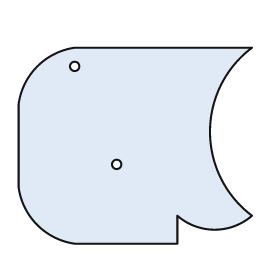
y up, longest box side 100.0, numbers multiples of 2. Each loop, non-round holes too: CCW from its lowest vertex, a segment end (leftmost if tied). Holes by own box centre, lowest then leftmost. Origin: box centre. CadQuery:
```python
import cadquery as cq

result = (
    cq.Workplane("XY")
    .moveTo(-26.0, -42.0)
    .lineTo(18.0, -42.0)
    .lineTo(18.0, -30.0)
    .threePointArc((34.0, -36.0), (50.0, -30.0))
    .threePointArc((32.0, 6.0), (50.0, 42.0))
    .lineTo(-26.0, 42.0)
    .threePointArc((-42.0, 34.0), (-50.0, 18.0))
    .lineTo(-50.0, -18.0)
    .threePointArc((-42.0, -34.0), (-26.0, -42.0))
    .close()
    .moveTo(-8.0, -8.0)
    .circle(2.0)
    .moveTo(-26.0, 34.0)
    .circle(2.0)
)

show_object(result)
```